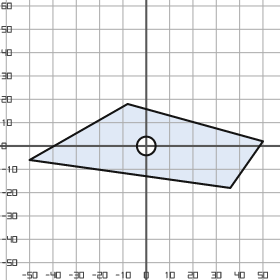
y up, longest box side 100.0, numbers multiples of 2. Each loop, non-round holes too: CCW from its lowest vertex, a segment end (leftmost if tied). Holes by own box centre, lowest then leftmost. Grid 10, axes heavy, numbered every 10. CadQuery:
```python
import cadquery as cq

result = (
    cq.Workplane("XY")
    .moveTo(36.0, -18.0)
    .lineTo(50.0, 2.0)
    .lineTo(-8.0, 18.0)
    .lineTo(-50.0, -6.0)
    .close()
    .moveTo(0.0, 0.0)
    .circle(4.0)
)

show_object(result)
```